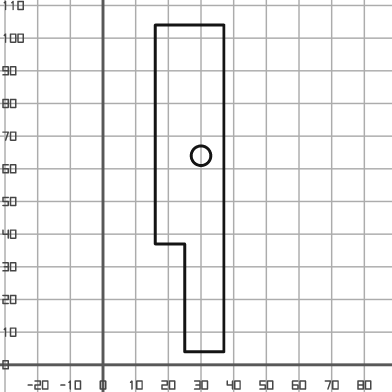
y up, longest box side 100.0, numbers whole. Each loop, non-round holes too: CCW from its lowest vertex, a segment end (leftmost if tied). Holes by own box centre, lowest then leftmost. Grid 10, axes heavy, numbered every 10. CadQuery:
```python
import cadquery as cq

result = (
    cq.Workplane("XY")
    .moveTo(25.0, 4.0)
    .lineTo(37.0, 4.0)
    .lineTo(37.0, 104.0)
    .lineTo(16.0, 104.0)
    .lineTo(16.0, 37.0)
    .lineTo(25.0, 37.0)
    .close()
    .moveTo(30.0, 64.0)
    .circle(3.0)
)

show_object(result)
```